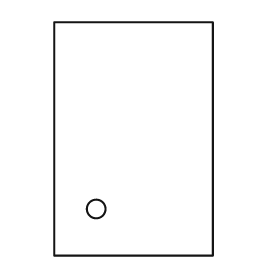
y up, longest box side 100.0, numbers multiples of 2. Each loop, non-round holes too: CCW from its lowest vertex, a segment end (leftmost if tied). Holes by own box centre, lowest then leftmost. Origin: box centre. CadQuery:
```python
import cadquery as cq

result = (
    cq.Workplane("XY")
    .moveTo(-34.0, -50.0)
    .lineTo(34.0, -50.0)
    .lineTo(34.0, 50.0)
    .lineTo(-34.0, 50.0)
    .close()
    .moveTo(-16.0, -30.0)
    .circle(4.0)
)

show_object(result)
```